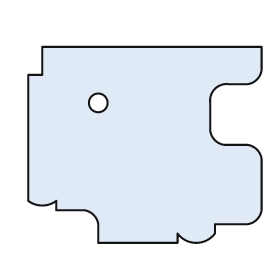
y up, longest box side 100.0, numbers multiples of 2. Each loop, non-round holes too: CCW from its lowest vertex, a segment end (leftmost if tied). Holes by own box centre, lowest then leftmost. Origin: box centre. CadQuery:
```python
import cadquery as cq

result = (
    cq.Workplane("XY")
    .moveTo(-20.0, -42.0)
    .lineTo(14.0, -42.0)
    .lineTo(14.0, -38.0)
    .threePointArc((22.0, -42.0), (30.0, -38.0))
    .lineTo(30.0, -34.0)
    .lineTo(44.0, -34.0)
    .threePointArc((48.0, -32.0), (50.0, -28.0))
    .lineTo(50.0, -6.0)
    .threePointArc((48.0, -2.0), (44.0, 0.0))
    .lineTo(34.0, 0.0)
    .threePointArc((30.0, 2.0), (28.0, 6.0))
    .lineTo(28.0, 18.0)
    .threePointArc((30.0, 24.0), (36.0, 26.0))
    .lineTo(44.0, 26.0)
    .threePointArc((48.0, 28.0), (50.0, 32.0))
    .lineTo(50.0, 42.0)
    .lineTo(-44.0, 42.0)
    .lineTo(-44.0, 30.0)
    .lineTo(-50.0, 30.0)
    .lineTo(-50.0, -24.0)
    .threePointArc((-44.0, -26.0), (-38.0, -24.0))
    .lineTo(-38.0, -28.0)
    .lineTo(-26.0, -28.0)
    .threePointArc((-22.0, -30.0), (-20.0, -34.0))
    .close()
    .moveTo(-20.0, 18.0)
    .circle(4.0)
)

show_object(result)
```